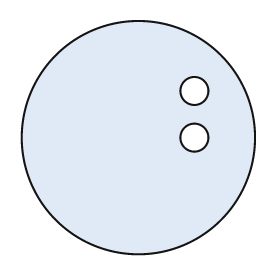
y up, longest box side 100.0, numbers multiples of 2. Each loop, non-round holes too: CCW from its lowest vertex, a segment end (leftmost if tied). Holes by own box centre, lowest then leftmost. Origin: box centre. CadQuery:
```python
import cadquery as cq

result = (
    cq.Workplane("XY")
    .moveTo(0.0, 0.0)
    .circle(50.0)
    .moveTo(24.0, 0.0)
    .circle(6.0)
    .moveTo(24.0, 20.0)
    .circle(6.0)
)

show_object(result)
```